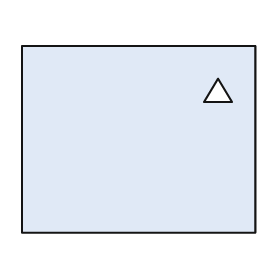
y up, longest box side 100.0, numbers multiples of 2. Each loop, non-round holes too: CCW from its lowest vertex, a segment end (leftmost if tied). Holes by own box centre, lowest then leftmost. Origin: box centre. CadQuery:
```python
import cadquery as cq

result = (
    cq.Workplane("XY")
    .moveTo(-50.0, -40.0)
    .lineTo(50.0, -40.0)
    .lineTo(50.0, 40.0)
    .lineTo(-50.0, 40.0)
    .close()
    .moveTo(28.0, 16.0)
    .lineTo(40.0, 16.0)
    .lineTo(34.0, 26.0)
    .close()
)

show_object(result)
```